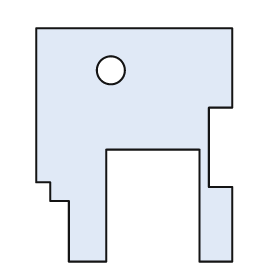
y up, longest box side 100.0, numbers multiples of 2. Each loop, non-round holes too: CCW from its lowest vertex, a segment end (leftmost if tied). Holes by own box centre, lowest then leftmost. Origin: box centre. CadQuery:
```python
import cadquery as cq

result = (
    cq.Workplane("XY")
    .moveTo(-28.0, -50.0)
    .lineTo(-12.0, -50.0)
    .lineTo(-12.0, -2.0)
    .lineTo(28.0, -2.0)
    .lineTo(28.0, -50.0)
    .lineTo(42.0, -50.0)
    .lineTo(42.0, -18.0)
    .lineTo(32.0, -18.0)
    .lineTo(32.0, 16.0)
    .lineTo(42.0, 16.0)
    .lineTo(42.0, 50.0)
    .lineTo(-42.0, 50.0)
    .lineTo(-42.0, -16.0)
    .lineTo(-36.0, -16.0)
    .lineTo(-36.0, -24.0)
    .lineTo(-28.0, -24.0)
    .close()
    .moveTo(-10.0, 32.0)
    .circle(6.0)
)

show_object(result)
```